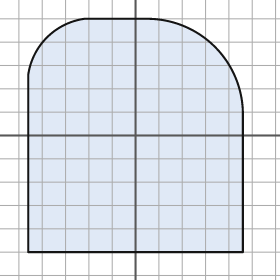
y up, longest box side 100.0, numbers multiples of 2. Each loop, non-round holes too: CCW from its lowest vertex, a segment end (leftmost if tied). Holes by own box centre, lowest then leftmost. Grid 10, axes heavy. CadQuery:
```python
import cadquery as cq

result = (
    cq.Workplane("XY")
    .moveTo(-46.0, -50.0)
    .lineTo(46.0, -50.0)
    .lineTo(46.0, 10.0)
    .threePointArc((34.0, 38.0), (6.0, 50.0))
    .lineTo(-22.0, 50.0)
    .threePointArc((-38.0, 42.0), (-46.0, 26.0))
    .close()
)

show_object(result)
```